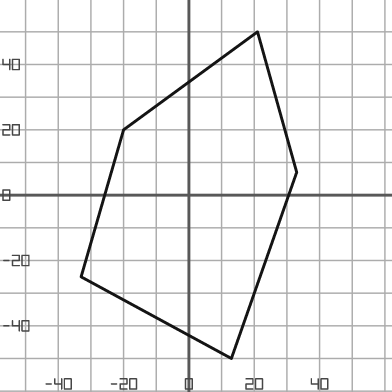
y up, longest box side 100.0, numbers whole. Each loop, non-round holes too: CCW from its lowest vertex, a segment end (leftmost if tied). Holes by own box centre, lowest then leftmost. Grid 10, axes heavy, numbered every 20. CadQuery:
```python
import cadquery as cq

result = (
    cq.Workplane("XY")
    .moveTo(13.0, -50.0)
    .lineTo(33.0, 7.0)
    .lineTo(21.0, 50.0)
    .lineTo(-20.0, 20.0)
    .lineTo(-33.0, -25.0)
    .close()
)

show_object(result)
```